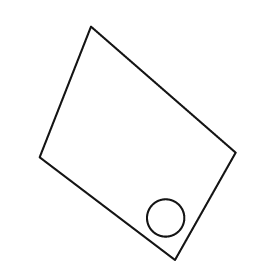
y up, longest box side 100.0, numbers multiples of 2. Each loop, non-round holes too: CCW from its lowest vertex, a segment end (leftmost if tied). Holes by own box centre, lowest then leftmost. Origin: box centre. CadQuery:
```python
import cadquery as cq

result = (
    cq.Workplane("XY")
    .moveTo(16.0, -50.0)
    .lineTo(42.0, -4.0)
    .lineTo(-20.0, 50.0)
    .lineTo(-42.0, -6.0)
    .close()
    .moveTo(12.0, -32.0)
    .circle(8.0)
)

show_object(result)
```